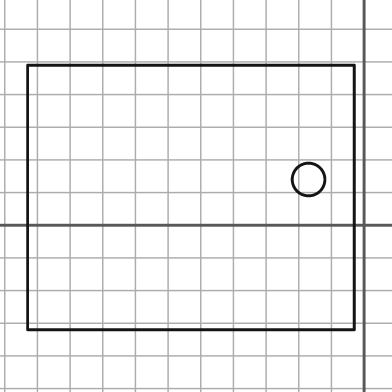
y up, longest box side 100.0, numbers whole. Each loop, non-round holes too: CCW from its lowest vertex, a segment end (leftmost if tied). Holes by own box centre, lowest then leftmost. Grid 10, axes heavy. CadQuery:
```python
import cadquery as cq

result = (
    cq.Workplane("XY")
    .moveTo(-103.0, -32.0)
    .lineTo(-3.0, -32.0)
    .lineTo(-3.0, 49.0)
    .lineTo(-103.0, 49.0)
    .close()
    .moveTo(-17.0, 14.0)
    .circle(5.0)
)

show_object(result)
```